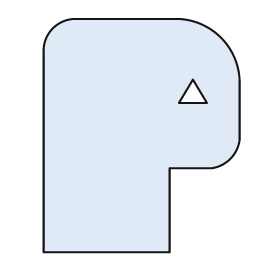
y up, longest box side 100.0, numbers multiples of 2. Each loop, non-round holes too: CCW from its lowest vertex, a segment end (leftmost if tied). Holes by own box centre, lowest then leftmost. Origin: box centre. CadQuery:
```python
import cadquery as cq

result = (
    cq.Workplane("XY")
    .moveTo(-42.0, -50.0)
    .lineTo(12.0, -50.0)
    .lineTo(12.0, -14.0)
    .lineTo(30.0, -14.0)
    .threePointArc((38.0, -10.0), (42.0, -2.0))
    .lineTo(42.0, 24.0)
    .threePointArc((34.0, 42.0), (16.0, 50.0))
    .lineTo(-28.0, 50.0)
    .threePointArc((-38.0, 46.0), (-42.0, 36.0))
    .close()
    .moveTo(16.0, 14.0)
    .lineTo(28.0, 14.0)
    .lineTo(22.0, 24.0)
    .close()
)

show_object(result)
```